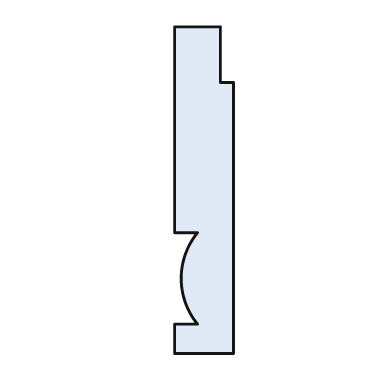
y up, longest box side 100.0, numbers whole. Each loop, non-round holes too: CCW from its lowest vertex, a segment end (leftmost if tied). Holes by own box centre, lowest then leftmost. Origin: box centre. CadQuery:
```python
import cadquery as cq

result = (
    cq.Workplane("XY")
    .moveTo(-9.0, -50.0)
    .lineTo(9.0, -50.0)
    .lineTo(9.0, 33.0)
    .lineTo(5.0, 33.0)
    .lineTo(5.0, 50.0)
    .lineTo(-9.0, 50.0)
    .lineTo(-9.0, -13.0)
    .lineTo(-2.0, -13.0)
    .threePointArc((-7.0, -27.0), (-2.0, -41.0))
    .lineTo(-9.0, -41.0)
    .close()
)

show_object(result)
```